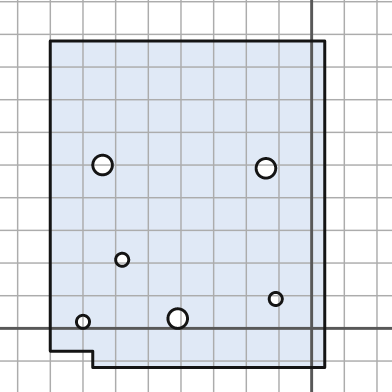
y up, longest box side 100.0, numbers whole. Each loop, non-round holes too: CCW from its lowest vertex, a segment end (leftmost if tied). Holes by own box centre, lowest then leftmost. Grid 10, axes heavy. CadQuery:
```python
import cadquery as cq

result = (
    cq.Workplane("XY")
    .moveTo(-67.0, -12.0)
    .lineTo(4.0, -12.0)
    .lineTo(4.0, 88.0)
    .lineTo(-80.0, 88.0)
    .lineTo(-80.0, -7.0)
    .lineTo(-67.0, -7.0)
    .close()
    .moveTo(-70.0, 2.0)
    .circle(2.0)
    .moveTo(-41.0, 3.0)
    .circle(3.0)
    .moveTo(-11.0, 9.0)
    .circle(2.0)
    .moveTo(-58.0, 21.0)
    .circle(2.0)
    .moveTo(-14.0, 49.0)
    .circle(3.0)
    .moveTo(-64.0, 50.0)
    .circle(3.0)
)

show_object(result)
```